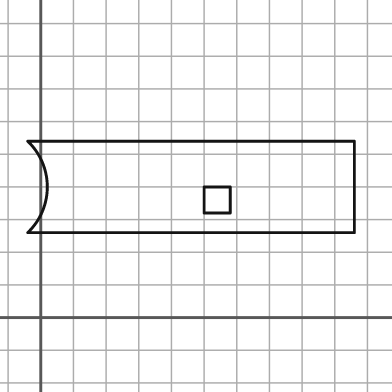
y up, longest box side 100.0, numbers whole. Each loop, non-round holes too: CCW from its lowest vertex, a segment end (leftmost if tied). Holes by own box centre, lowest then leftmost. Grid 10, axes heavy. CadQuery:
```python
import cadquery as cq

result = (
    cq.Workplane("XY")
    .moveTo(-4.0, 26.0)
    .lineTo(96.0, 26.0)
    .lineTo(96.0, 54.0)
    .lineTo(-4.0, 54.0)
    .threePointArc((2.0, 40.0), (-4.0, 26.0))
    .close()
    .moveTo(50.0, 32.0)
    .lineTo(58.0, 32.0)
    .lineTo(58.0, 40.0)
    .lineTo(50.0, 40.0)
    .close()
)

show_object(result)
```